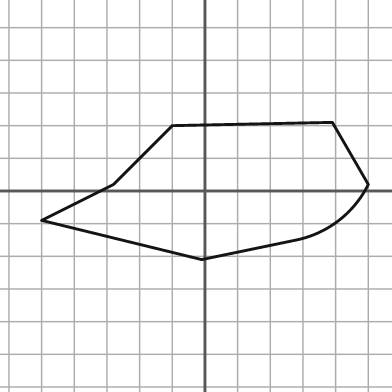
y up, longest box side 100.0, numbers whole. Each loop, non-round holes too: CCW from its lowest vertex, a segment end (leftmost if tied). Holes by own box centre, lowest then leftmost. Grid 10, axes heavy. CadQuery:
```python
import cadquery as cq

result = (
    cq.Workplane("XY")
    .moveTo(-1.0, -21.0)
    .lineTo(28.0, -15.0)
    .threePointArc((41.0, -9.0), (50.0, 2.0))
    .lineTo(39.0, 21.0)
    .lineTo(-10.0, 20.0)
    .lineTo(-28.0, 2.0)
    .lineTo(-50.0, -9.0)
    .close()
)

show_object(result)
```